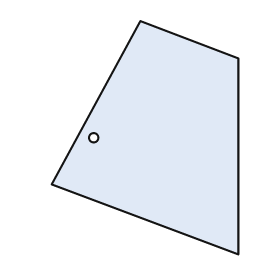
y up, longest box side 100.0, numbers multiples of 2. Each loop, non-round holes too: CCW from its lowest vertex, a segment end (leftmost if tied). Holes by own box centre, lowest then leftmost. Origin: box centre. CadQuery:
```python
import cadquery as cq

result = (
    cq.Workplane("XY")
    .moveTo(40.0, -50.0)
    .lineTo(40.0, 34.0)
    .lineTo(-2.0, 50.0)
    .lineTo(-40.0, -20.0)
    .close()
    .moveTo(-22.0, 0.0)
    .circle(2.0)
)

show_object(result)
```